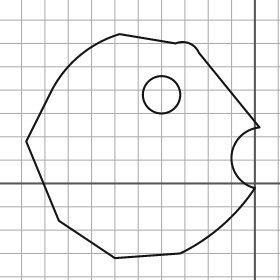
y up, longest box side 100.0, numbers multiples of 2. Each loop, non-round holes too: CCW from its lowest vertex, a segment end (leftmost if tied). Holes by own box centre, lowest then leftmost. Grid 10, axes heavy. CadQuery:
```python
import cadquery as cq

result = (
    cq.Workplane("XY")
    .moveTo(-60.0, -32.0)
    .lineTo(-32.0, -30.0)
    .threePointArc((-14.0, -18.0), (0.0, -2.0))
    .threePointArc((-10.0, 12.0), (2.0, 24.0))
    .lineTo(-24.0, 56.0)
    .threePointArc((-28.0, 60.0), (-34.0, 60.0))
    .lineTo(-58.0, 64.0)
    .threePointArc((-76.0, 54.0), (-88.0, 38.0))
    .lineTo(-98.0, 18.0)
    .lineTo(-84.0, -16.0)
    .close()
    .moveTo(-40.0, 38.0)
    .circle(8.0)
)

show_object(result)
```